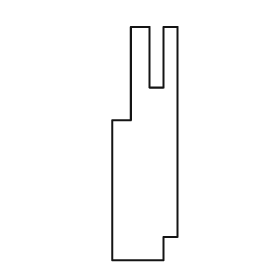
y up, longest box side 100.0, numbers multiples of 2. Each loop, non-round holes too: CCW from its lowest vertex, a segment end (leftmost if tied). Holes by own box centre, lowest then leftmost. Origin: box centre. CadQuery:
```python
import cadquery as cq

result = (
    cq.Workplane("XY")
    .moveTo(-14.0, -50.0)
    .lineTo(8.0, -50.0)
    .lineTo(8.0, -40.0)
    .lineTo(14.0, -40.0)
    .lineTo(14.0, 50.0)
    .lineTo(8.0, 50.0)
    .lineTo(8.0, 24.0)
    .lineTo(2.0, 24.0)
    .lineTo(2.0, 50.0)
    .lineTo(-6.0, 50.0)
    .lineTo(-6.0, 10.0)
    .lineTo(-14.0, 10.0)
    .close()
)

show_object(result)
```